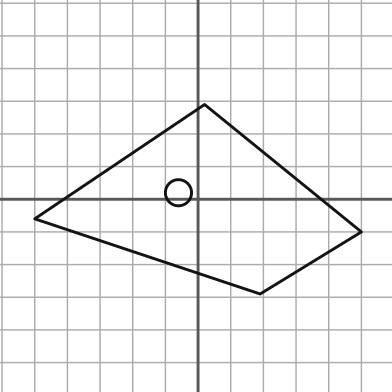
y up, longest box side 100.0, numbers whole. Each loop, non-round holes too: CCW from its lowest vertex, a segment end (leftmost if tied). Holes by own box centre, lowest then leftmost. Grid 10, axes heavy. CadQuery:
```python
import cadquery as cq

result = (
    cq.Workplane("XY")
    .moveTo(19.0, -29.0)
    .lineTo(50.0, -10.0)
    .lineTo(2.0, 29.0)
    .lineTo(-50.0, -6.0)
    .close()
    .moveTo(-6.0, 2.0)
    .circle(4.0)
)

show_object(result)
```